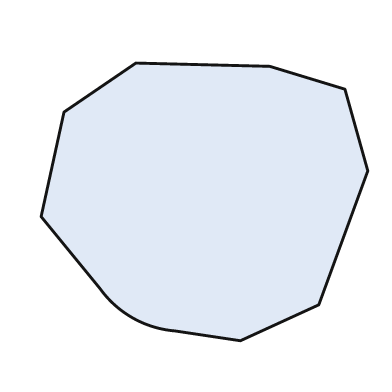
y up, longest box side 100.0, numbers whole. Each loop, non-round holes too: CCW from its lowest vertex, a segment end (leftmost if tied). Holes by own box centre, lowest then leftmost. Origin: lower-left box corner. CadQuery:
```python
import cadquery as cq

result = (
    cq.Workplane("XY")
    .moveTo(61.0, 0.0)
    .lineTo(85.0, 11.0)
    .lineTo(100.0, 52.0)
    .lineTo(93.0, 77.0)
    .lineTo(70.0, 84.0)
    .lineTo(29.0, 85.0)
    .lineTo(7.0, 70.0)
    .lineTo(0.0, 38.0)
    .lineTo(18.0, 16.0)
    .threePointArc((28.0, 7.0), (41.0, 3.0))
    .close()
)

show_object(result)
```